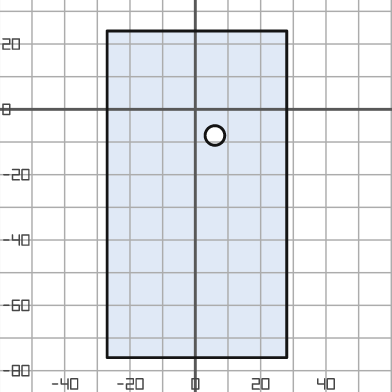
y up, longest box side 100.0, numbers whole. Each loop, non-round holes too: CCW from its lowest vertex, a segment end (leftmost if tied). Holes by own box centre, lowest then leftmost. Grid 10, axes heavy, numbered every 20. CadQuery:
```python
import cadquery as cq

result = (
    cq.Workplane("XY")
    .moveTo(-27.0, -76.0)
    .lineTo(28.0, -76.0)
    .lineTo(28.0, 24.0)
    .lineTo(-27.0, 24.0)
    .close()
    .moveTo(6.0, -8.0)
    .circle(3.0)
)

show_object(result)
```